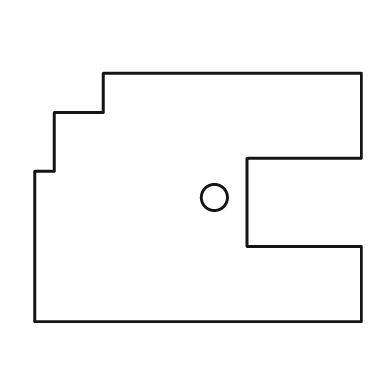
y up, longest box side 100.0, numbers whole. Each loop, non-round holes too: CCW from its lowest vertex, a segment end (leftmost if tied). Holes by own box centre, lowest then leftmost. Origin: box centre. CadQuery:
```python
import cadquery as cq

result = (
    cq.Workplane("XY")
    .moveTo(-50.0, -38.0)
    .lineTo(50.0, -38.0)
    .lineTo(50.0, -15.0)
    .lineTo(15.0, -15.0)
    .lineTo(15.0, 12.0)
    .lineTo(50.0, 12.0)
    .lineTo(50.0, 38.0)
    .lineTo(-29.0, 38.0)
    .lineTo(-29.0, 26.0)
    .lineTo(-44.0, 26.0)
    .lineTo(-44.0, 8.0)
    .lineTo(-50.0, 8.0)
    .close()
    .moveTo(5.0, 0.0)
    .circle(4.0)
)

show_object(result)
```